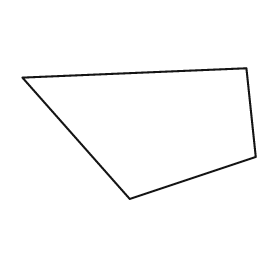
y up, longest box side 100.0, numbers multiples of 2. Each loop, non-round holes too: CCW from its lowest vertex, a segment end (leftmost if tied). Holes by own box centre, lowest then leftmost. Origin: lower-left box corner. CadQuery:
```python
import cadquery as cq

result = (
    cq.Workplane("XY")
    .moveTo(46.0, 0.0)
    .lineTo(100.0, 18.0)
    .lineTo(96.0, 56.0)
    .lineTo(0.0, 52.0)
    .close()
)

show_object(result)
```